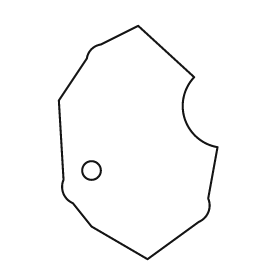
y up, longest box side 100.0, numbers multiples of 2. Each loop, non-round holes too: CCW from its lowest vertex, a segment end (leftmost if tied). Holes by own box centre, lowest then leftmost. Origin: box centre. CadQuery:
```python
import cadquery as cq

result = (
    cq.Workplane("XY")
    .moveTo(4.0, -50.0)
    .lineTo(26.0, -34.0)
    .threePointArc((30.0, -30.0), (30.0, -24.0))
    .lineTo(34.0, -2.0)
    .threePointArc((20.0, 10.0), (24.0, 28.0))
    .lineTo(0.0, 50.0)
    .lineTo(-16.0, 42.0)
    .threePointArc((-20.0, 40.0), (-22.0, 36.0))
    .lineTo(-34.0, 18.0)
    .lineTo(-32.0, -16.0)
    .threePointArc((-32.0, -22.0), (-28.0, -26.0))
    .lineTo(-20.0, -36.0)
    .close()
    .moveTo(-20.0, -12.0)
    .circle(4.0)
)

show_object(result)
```